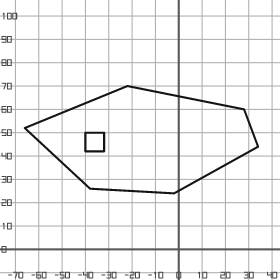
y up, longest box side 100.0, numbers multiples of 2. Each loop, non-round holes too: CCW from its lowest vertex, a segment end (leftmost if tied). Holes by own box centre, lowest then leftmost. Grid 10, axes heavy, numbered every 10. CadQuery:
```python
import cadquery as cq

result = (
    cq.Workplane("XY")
    .moveTo(-2.0, 24.0)
    .lineTo(34.0, 44.0)
    .lineTo(28.0, 60.0)
    .lineTo(-22.0, 70.0)
    .lineTo(-66.0, 52.0)
    .lineTo(-38.0, 26.0)
    .close()
    .moveTo(-40.0, 42.0)
    .lineTo(-32.0, 42.0)
    .lineTo(-32.0, 50.0)
    .lineTo(-40.0, 50.0)
    .close()
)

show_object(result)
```